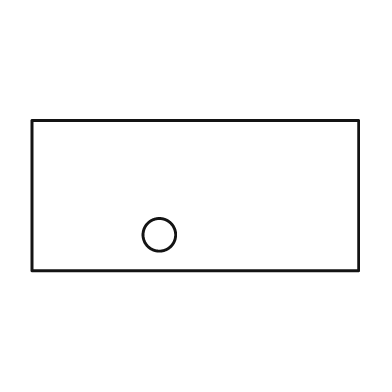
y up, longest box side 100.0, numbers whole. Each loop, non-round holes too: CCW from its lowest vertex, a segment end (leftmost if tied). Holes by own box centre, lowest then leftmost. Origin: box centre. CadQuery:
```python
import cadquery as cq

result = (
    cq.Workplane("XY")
    .moveTo(-50.0, -23.0)
    .lineTo(50.0, -23.0)
    .lineTo(50.0, 23.0)
    .lineTo(-50.0, 23.0)
    .close()
    .moveTo(-11.0, -12.0)
    .circle(5.0)
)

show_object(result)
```